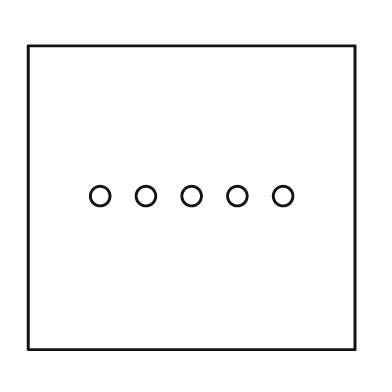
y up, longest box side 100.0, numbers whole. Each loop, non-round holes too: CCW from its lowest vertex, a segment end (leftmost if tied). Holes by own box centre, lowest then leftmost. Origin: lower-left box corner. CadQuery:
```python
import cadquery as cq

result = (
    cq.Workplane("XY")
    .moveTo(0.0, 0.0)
    .lineTo(100.0, 0.0)
    .lineTo(100.0, 93.0)
    .lineTo(0.0, 93.0)
    .close()
    .moveTo(22.0, 47.0)
    .circle(3.0)
    .moveTo(36.0, 47.0)
    .circle(3.0)
    .moveTo(50.0, 47.0)
    .circle(3.0)
    .moveTo(64.0, 47.0)
    .circle(3.0)
    .moveTo(78.0, 47.0)
    .circle(3.0)
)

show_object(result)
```